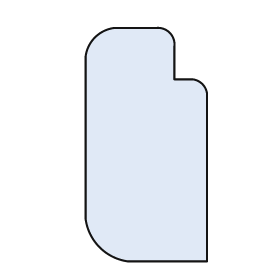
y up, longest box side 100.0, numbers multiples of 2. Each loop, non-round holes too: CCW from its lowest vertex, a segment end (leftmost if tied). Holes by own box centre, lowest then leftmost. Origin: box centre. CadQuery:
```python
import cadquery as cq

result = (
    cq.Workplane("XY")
    .moveTo(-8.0, -50.0)
    .lineTo(26.0, -50.0)
    .lineTo(26.0, 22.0)
    .threePointArc((24.0, 26.0), (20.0, 28.0))
    .lineTo(12.0, 28.0)
    .lineTo(12.0, 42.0)
    .threePointArc((10.0, 48.0), (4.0, 50.0))
    .lineTo(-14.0, 50.0)
    .threePointArc((-22.0, 46.0), (-26.0, 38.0))
    .lineTo(-26.0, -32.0)
    .threePointArc((-20.0, -44.0), (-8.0, -50.0))
    .close()
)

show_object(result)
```